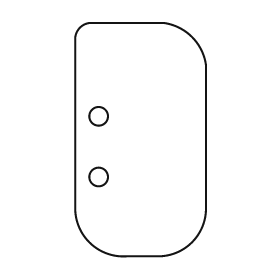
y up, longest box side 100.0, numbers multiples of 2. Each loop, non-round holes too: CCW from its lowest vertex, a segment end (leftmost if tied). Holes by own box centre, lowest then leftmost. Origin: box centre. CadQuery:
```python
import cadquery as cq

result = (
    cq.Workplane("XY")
    .moveTo(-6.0, -50.0)
    .lineTo(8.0, -50.0)
    .threePointArc((22.0, -44.0), (28.0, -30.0))
    .lineTo(28.0, 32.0)
    .threePointArc((22.0, 44.0), (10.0, 50.0))
    .lineTo(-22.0, 50.0)
    .threePointArc((-26.0, 48.0), (-28.0, 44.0))
    .lineTo(-28.0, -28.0)
    .threePointArc((-22.0, -44.0), (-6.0, -50.0))
    .close()
    .moveTo(-18.0, -16.0)
    .circle(4.0)
    .moveTo(-18.0, 10.0)
    .circle(4.0)
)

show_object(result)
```